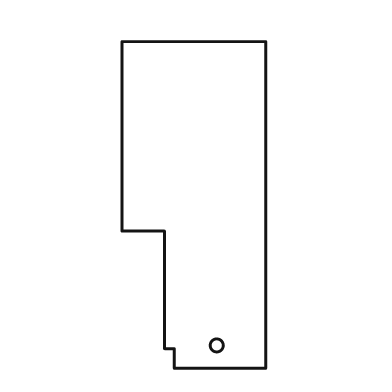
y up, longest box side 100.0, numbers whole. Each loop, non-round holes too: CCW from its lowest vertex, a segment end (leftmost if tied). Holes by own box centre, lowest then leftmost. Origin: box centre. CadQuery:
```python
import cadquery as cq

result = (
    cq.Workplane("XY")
    .moveTo(-6.0, -50.0)
    .lineTo(22.0, -50.0)
    .lineTo(22.0, 50.0)
    .lineTo(-22.0, 50.0)
    .lineTo(-22.0, -8.0)
    .lineTo(-9.0, -8.0)
    .lineTo(-9.0, -44.0)
    .lineTo(-6.0, -44.0)
    .close()
    .moveTo(7.0, -43.0)
    .circle(2.0)
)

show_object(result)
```